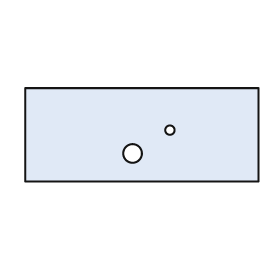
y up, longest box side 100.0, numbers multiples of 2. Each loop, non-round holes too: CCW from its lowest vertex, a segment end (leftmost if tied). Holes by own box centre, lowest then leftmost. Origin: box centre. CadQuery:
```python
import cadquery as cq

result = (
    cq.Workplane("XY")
    .moveTo(-50.0, -20.0)
    .lineTo(50.0, -20.0)
    .lineTo(50.0, 20.0)
    .lineTo(-50.0, 20.0)
    .close()
    .moveTo(-4.0, -8.0)
    .circle(4.0)
    .moveTo(12.0, 2.0)
    .circle(2.0)
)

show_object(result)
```